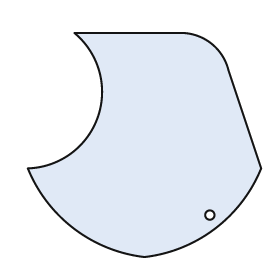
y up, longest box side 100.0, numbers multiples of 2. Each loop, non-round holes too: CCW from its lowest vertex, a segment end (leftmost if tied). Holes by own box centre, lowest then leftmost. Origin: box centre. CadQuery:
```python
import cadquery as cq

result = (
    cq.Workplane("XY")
    .moveTo(0.0, -48.0)
    .threePointArc((30.0, -36.0), (50.0, -10.0))
    .lineTo(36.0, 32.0)
    .threePointArc((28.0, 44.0), (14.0, 48.0))
    .lineTo(-30.0, 48.0)
    .threePointArc((-20.0, 12.0), (-50.0, -10.0))
    .threePointArc((-30.0, -36.0), (0.0, -48.0))
    .close()
    .moveTo(28.0, -30.0)
    .circle(2.0)
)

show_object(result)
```